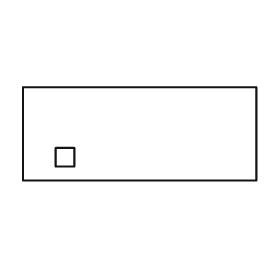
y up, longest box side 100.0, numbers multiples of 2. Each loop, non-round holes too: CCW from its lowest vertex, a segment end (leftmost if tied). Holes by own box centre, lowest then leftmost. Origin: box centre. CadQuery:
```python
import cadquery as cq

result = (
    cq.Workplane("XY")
    .moveTo(-50.0, -20.0)
    .lineTo(50.0, -20.0)
    .lineTo(50.0, 20.0)
    .lineTo(-50.0, 20.0)
    .close()
    .moveTo(-36.0, -14.0)
    .lineTo(-28.0, -14.0)
    .lineTo(-28.0, -6.0)
    .lineTo(-36.0, -6.0)
    .close()
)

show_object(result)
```